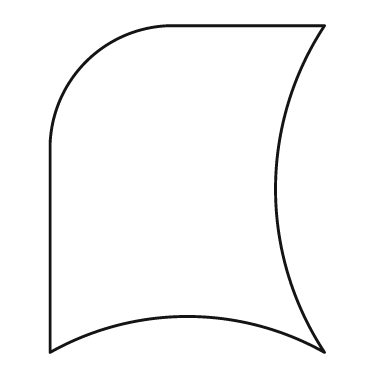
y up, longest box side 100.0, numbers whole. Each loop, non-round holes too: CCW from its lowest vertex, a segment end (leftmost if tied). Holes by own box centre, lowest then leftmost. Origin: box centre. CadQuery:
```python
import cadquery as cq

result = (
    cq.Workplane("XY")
    .moveTo(-42.0, -50.0)
    .threePointArc((0.0, -39.0), (42.0, -50.0))
    .threePointArc((27.0, 0.0), (42.0, 50.0))
    .lineTo(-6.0, 50.0)
    .threePointArc((-31.0, 39.0), (-42.0, 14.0))
    .close()
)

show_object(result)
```